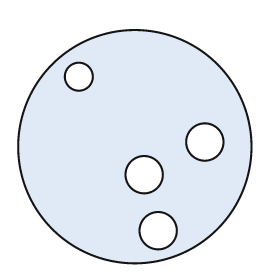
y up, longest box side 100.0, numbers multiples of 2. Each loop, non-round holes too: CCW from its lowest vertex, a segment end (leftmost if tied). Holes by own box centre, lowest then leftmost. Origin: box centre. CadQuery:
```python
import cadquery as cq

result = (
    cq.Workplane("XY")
    .moveTo(0.0, 0.0)
    .circle(50.0)
    .moveTo(10.0, -36.0)
    .circle(8.0)
    .moveTo(4.0, -12.0)
    .circle(8.0)
    .moveTo(30.0, 2.0)
    .circle(8.0)
    .moveTo(-24.0, 30.0)
    .circle(6.0)
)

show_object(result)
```